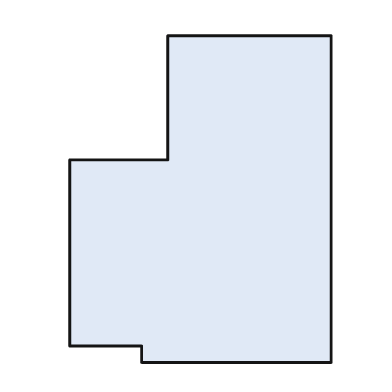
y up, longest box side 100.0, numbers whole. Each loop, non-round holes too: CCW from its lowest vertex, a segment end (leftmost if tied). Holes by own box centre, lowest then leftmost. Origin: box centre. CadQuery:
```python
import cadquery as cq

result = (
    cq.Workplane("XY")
    .moveTo(-18.0, -50.0)
    .lineTo(40.0, -50.0)
    .lineTo(40.0, 50.0)
    .lineTo(-10.0, 50.0)
    .lineTo(-10.0, 12.0)
    .lineTo(-40.0, 12.0)
    .lineTo(-40.0, -45.0)
    .lineTo(-18.0, -45.0)
    .close()
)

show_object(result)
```